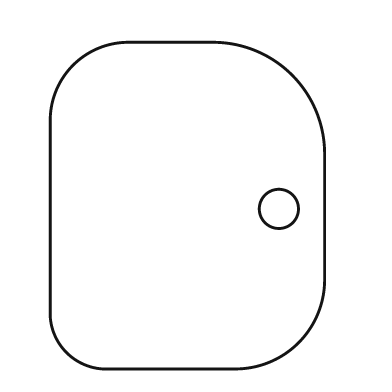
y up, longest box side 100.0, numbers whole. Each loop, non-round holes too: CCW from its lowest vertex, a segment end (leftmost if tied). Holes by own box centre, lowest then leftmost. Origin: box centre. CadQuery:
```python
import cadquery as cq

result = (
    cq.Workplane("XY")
    .moveTo(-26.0, -50.0)
    .lineTo(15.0, -50.0)
    .threePointArc((34.0, -42.0), (42.0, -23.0))
    .lineTo(42.0, 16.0)
    .threePointArc((32.0, 40.0), (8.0, 50.0))
    .lineTo(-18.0, 50.0)
    .threePointArc((-35.0, 43.0), (-42.0, 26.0))
    .lineTo(-42.0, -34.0)
    .threePointArc((-37.0, -45.0), (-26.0, -50.0))
    .close()
    .moveTo(28.0, -1.0)
    .circle(6.0)
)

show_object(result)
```